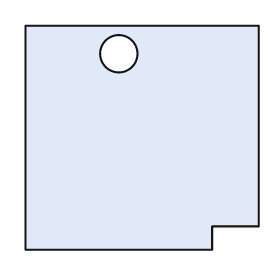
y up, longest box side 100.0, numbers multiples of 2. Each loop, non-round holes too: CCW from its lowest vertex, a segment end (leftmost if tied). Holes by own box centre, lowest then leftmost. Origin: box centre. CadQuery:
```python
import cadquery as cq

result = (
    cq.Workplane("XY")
    .moveTo(-50.0, -48.0)
    .lineTo(30.0, -48.0)
    .lineTo(30.0, -38.0)
    .lineTo(50.0, -38.0)
    .lineTo(50.0, 48.0)
    .lineTo(-50.0, 48.0)
    .close()
    .moveTo(-10.0, 36.0)
    .circle(8.0)
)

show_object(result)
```